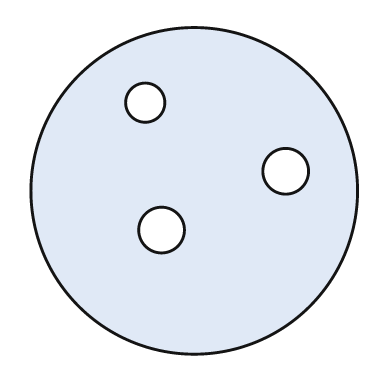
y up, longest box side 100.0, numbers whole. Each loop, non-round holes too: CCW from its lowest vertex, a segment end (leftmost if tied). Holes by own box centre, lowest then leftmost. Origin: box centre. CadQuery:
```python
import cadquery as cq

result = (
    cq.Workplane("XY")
    .moveTo(0.0, 0.0)
    .circle(50.0)
    .moveTo(-10.0, -12.0)
    .circle(7.0)
    .moveTo(28.0, 6.0)
    .circle(7.0)
    .moveTo(-15.0, 27.0)
    .circle(6.0)
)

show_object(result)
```